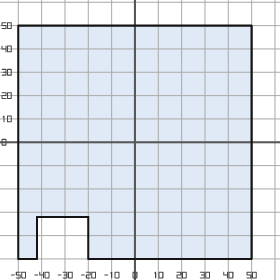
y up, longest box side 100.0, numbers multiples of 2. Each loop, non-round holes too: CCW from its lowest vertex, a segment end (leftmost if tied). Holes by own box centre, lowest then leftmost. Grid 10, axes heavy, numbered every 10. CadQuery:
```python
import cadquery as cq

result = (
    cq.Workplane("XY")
    .moveTo(-50.0, -50.0)
    .lineTo(-42.0, -50.0)
    .lineTo(-42.0, -32.0)
    .lineTo(-20.0, -32.0)
    .lineTo(-20.0, -50.0)
    .lineTo(50.0, -50.0)
    .lineTo(50.0, 50.0)
    .lineTo(-50.0, 50.0)
    .close()
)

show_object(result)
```